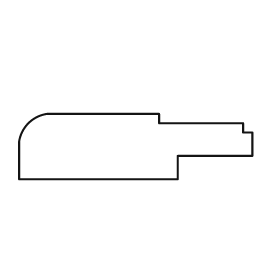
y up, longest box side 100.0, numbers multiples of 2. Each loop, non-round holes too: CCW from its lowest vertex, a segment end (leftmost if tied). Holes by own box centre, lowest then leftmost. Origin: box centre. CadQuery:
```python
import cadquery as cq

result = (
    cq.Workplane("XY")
    .moveTo(-50.0, -14.0)
    .lineTo(18.0, -14.0)
    .lineTo(18.0, -4.0)
    .lineTo(50.0, -4.0)
    .lineTo(50.0, 6.0)
    .lineTo(46.0, 6.0)
    .lineTo(46.0, 10.0)
    .lineTo(10.0, 10.0)
    .lineTo(10.0, 14.0)
    .lineTo(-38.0, 14.0)
    .threePointArc((-46.0, 10.0), (-50.0, 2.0))
    .close()
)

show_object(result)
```